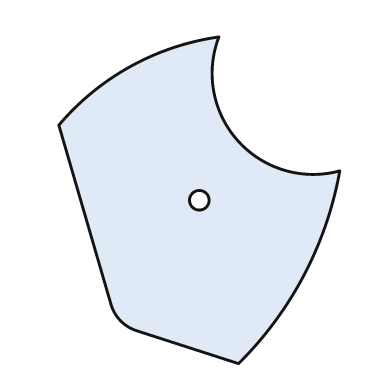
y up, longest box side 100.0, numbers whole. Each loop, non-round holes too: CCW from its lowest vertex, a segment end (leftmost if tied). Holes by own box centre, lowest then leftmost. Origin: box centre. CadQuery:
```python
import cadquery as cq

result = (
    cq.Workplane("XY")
    .moveTo(12.0, -50.0)
    .threePointArc((32.0, -23.0), (43.0, 9.0))
    .threePointArc((12.0, 18.0), (6.0, 50.0))
    .threePointArc((-21.0, 41.0), (-43.0, 23.0))
    .lineTo(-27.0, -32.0)
    .threePointArc((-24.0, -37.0), (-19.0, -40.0))
    .close()
    .moveTo(0.0, 0.0)
    .circle(3.0)
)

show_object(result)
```